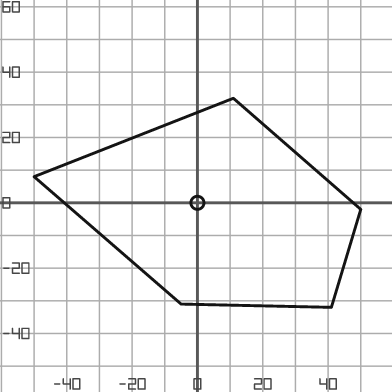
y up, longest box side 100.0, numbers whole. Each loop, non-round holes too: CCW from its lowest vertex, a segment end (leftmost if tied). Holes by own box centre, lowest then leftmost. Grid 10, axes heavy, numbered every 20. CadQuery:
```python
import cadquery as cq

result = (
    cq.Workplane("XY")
    .moveTo(41.0, -32.0)
    .lineTo(50.0, -2.0)
    .lineTo(11.0, 32.0)
    .lineTo(-50.0, 8.0)
    .lineTo(-5.0, -31.0)
    .close()
    .moveTo(0.0, 0.0)
    .circle(2.0)
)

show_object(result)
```